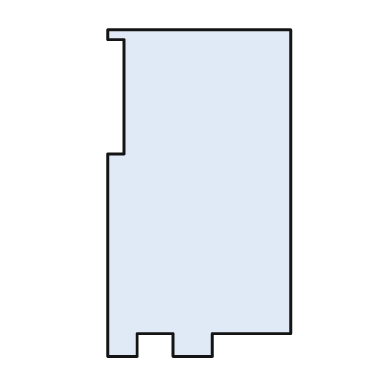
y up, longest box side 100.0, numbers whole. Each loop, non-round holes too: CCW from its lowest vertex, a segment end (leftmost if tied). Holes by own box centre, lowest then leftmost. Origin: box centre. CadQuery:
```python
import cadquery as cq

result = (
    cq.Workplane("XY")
    .moveTo(-28.0, -50.0)
    .lineTo(-19.0, -50.0)
    .lineTo(-19.0, -43.0)
    .lineTo(-8.0, -43.0)
    .lineTo(-8.0, -50.0)
    .lineTo(4.0, -50.0)
    .lineTo(4.0, -43.0)
    .lineTo(28.0, -43.0)
    .lineTo(28.0, 50.0)
    .lineTo(-28.0, 50.0)
    .lineTo(-28.0, 47.0)
    .lineTo(-23.0, 47.0)
    .lineTo(-23.0, 12.0)
    .lineTo(-28.0, 12.0)
    .close()
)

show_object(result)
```